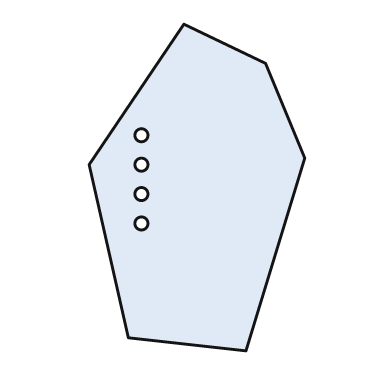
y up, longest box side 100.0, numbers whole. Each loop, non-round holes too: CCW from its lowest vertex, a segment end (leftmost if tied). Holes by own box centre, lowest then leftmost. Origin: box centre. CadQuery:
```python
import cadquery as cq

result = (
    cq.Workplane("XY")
    .moveTo(15.0, -50.0)
    .lineTo(33.0, 9.0)
    .lineTo(21.0, 38.0)
    .lineTo(-4.0, 50.0)
    .lineTo(-33.0, 7.0)
    .lineTo(-21.0, -46.0)
    .close()
    .moveTo(-17.0, -11.0)
    .circle(2.0)
    .moveTo(-17.0, -2.0)
    .circle(2.0)
    .moveTo(-17.0, 7.0)
    .circle(2.0)
    .moveTo(-17.0, 16.0)
    .circle(2.0)
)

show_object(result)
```